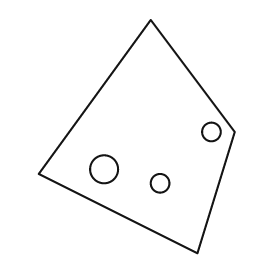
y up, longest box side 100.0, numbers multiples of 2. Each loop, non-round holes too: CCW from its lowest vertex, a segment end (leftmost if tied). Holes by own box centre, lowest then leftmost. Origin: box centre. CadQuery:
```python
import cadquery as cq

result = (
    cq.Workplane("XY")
    .moveTo(26.0, -50.0)
    .lineTo(42.0, 2.0)
    .lineTo(6.0, 50.0)
    .lineTo(-42.0, -16.0)
    .close()
    .moveTo(10.0, -20.0)
    .circle(4.0)
    .moveTo(-14.0, -14.0)
    .circle(6.0)
    .moveTo(32.0, 2.0)
    .circle(4.0)
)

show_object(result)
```